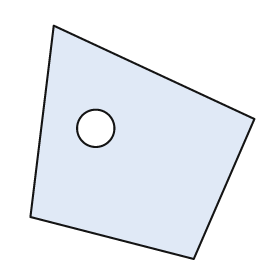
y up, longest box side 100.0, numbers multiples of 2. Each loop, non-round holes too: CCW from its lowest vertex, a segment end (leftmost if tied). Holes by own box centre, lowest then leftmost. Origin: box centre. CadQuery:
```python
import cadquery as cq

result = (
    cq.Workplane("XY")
    .moveTo(22.0, -50.0)
    .lineTo(48.0, 10.0)
    .lineTo(-38.0, 50.0)
    .lineTo(-48.0, -32.0)
    .close()
    .moveTo(-20.0, 6.0)
    .circle(8.0)
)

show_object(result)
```